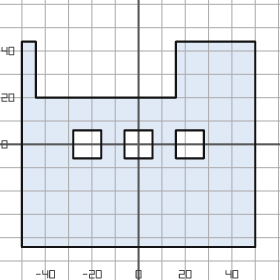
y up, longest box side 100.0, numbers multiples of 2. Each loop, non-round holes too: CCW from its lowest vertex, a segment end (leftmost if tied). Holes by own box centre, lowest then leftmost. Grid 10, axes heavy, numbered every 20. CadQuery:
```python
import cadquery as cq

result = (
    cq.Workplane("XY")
    .moveTo(-50.0, -44.0)
    .lineTo(50.0, -44.0)
    .lineTo(50.0, 44.0)
    .lineTo(16.0, 44.0)
    .lineTo(16.0, 20.0)
    .lineTo(-44.0, 20.0)
    .lineTo(-44.0, 44.0)
    .lineTo(-50.0, 44.0)
    .close()
    .moveTo(-28.0, -6.0)
    .lineTo(-16.0, -6.0)
    .lineTo(-16.0, 6.0)
    .lineTo(-28.0, 6.0)
    .close()
    .moveTo(-6.0, -6.0)
    .lineTo(6.0, -6.0)
    .lineTo(6.0, 6.0)
    .lineTo(-6.0, 6.0)
    .close()
    .moveTo(16.0, -6.0)
    .lineTo(28.0, -6.0)
    .lineTo(28.0, 6.0)
    .lineTo(16.0, 6.0)
    .close()
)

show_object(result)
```